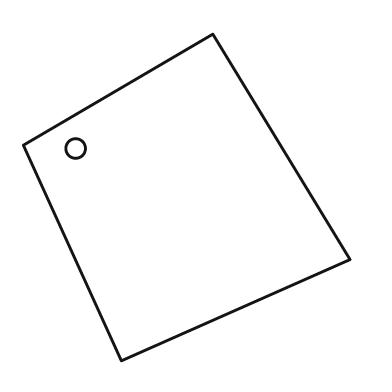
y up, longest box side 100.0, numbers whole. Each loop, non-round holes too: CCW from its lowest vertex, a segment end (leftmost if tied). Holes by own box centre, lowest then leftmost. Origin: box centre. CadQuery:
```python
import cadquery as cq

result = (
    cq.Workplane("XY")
    .moveTo(-20.0, -50.0)
    .lineTo(50.0, -19.0)
    .lineTo(8.0, 50.0)
    .lineTo(-50.0, 16.0)
    .close()
    .moveTo(-34.0, 15.0)
    .circle(3.0)
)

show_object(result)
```